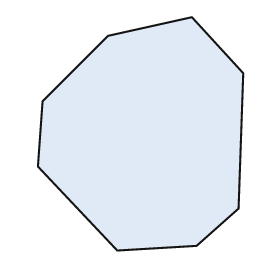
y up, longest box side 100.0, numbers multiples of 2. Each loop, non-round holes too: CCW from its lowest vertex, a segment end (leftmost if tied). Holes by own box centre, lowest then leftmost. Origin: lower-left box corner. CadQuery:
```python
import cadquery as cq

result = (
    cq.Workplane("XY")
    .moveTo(34.0, 0.0)
    .lineTo(68.0, 2.0)
    .lineTo(86.0, 18.0)
    .lineTo(88.0, 76.0)
    .lineTo(66.0, 100.0)
    .lineTo(30.0, 92.0)
    .lineTo(2.0, 64.0)
    .lineTo(0.0, 36.0)
    .close()
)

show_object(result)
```